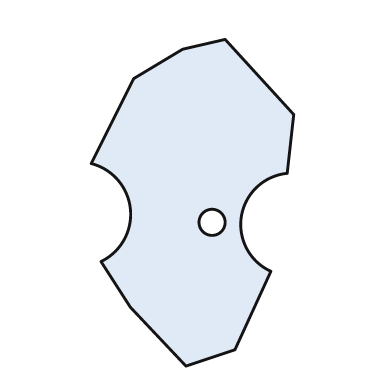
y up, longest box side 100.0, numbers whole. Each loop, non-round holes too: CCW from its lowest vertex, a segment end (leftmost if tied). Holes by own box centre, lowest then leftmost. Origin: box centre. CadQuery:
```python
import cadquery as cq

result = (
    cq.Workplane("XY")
    .moveTo(-2.0, -50.0)
    .lineTo(13.0, -45.0)
    .lineTo(24.0, -21.0)
    .threePointArc((15.0, -4.0), (29.0, 9.0))
    .lineTo(31.0, 27.0)
    .lineTo(10.0, 50.0)
    .lineTo(-3.0, 47.0)
    .lineTo(-18.0, 38.0)
    .lineTo(-31.0, 12.0)
    .threePointArc((-19.0, -2.0), (-28.0, -18.0))
    .lineTo(-19.0, -32.0)
    .close()
    .moveTo(6.0, -6.0)
    .circle(4.0)
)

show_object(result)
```